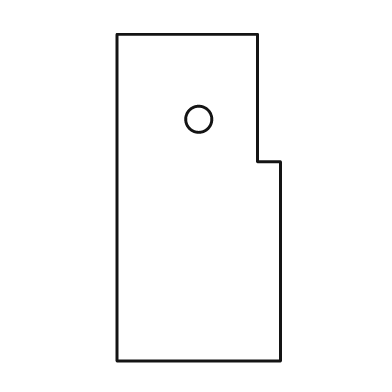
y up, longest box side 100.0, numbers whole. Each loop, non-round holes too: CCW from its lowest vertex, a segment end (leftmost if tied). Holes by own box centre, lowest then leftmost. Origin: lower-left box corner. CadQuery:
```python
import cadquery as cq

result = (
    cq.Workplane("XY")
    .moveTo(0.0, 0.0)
    .lineTo(50.0, 0.0)
    .lineTo(50.0, 61.0)
    .lineTo(43.0, 61.0)
    .lineTo(43.0, 100.0)
    .lineTo(0.0, 100.0)
    .close()
    .moveTo(25.0, 74.0)
    .circle(4.0)
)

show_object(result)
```